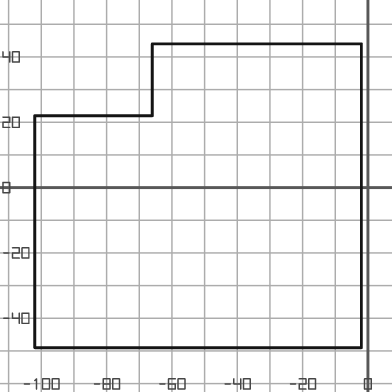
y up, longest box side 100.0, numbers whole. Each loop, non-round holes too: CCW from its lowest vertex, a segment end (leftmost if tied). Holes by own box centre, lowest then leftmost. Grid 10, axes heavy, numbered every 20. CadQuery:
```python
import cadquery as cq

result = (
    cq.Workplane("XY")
    .moveTo(-102.0, -49.0)
    .lineTo(-2.0, -49.0)
    .lineTo(-2.0, 44.0)
    .lineTo(-66.0, 44.0)
    .lineTo(-66.0, 22.0)
    .lineTo(-102.0, 22.0)
    .close()
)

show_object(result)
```